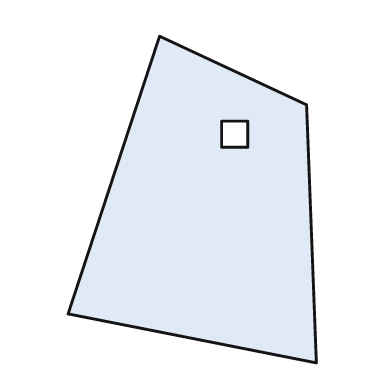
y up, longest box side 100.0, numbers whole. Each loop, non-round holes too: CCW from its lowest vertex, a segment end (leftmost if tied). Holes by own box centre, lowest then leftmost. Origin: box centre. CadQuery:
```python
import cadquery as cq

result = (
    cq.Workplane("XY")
    .moveTo(38.0, -50.0)
    .lineTo(35.0, 29.0)
    .lineTo(-10.0, 50.0)
    .lineTo(-38.0, -35.0)
    .close()
    .moveTo(9.0, 16.0)
    .lineTo(17.0, 16.0)
    .lineTo(17.0, 24.0)
    .lineTo(9.0, 24.0)
    .close()
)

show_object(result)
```